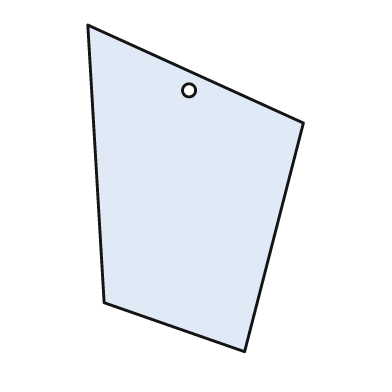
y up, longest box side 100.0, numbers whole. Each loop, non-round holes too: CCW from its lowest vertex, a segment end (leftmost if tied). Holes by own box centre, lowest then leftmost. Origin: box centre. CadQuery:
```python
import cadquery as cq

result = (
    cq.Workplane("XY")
    .moveTo(15.0, -50.0)
    .lineTo(33.0, 20.0)
    .lineTo(-33.0, 50.0)
    .lineTo(-28.0, -35.0)
    .close()
    .moveTo(-2.0, 30.0)
    .circle(2.0)
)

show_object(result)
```